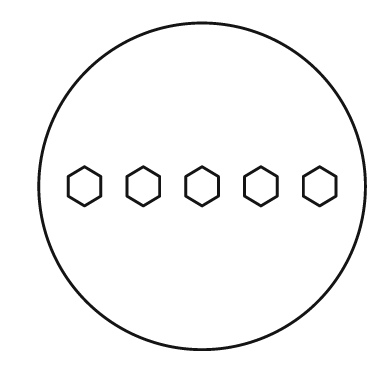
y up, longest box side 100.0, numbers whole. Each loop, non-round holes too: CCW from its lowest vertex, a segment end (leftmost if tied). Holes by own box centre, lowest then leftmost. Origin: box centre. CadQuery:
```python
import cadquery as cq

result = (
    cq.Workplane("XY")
    .moveTo(0.0, 0.0)
    .circle(50.0)
    .moveTo(-36.0, -6.0)
    .lineTo(-31.0, -3.0)
    .lineTo(-31.0, 3.0)
    .lineTo(-36.0, 6.0)
    .lineTo(-41.0, 3.0)
    .lineTo(-41.0, -3.0)
    .close()
    .moveTo(-18.0, -6.0)
    .lineTo(-13.0, -3.0)
    .lineTo(-13.0, 3.0)
    .lineTo(-18.0, 6.0)
    .lineTo(-23.0, 3.0)
    .lineTo(-23.0, -3.0)
    .close()
    .moveTo(0.0, -6.0)
    .lineTo(5.0, -3.0)
    .lineTo(5.0, 3.0)
    .lineTo(0.0, 6.0)
    .lineTo(-5.0, 3.0)
    .lineTo(-5.0, -3.0)
    .close()
    .moveTo(18.0, -6.0)
    .lineTo(23.0, -3.0)
    .lineTo(23.0, 3.0)
    .lineTo(18.0, 6.0)
    .lineTo(13.0, 3.0)
    .lineTo(13.0, -3.0)
    .close()
    .moveTo(36.0, -6.0)
    .lineTo(41.0, -3.0)
    .lineTo(41.0, 3.0)
    .lineTo(36.0, 6.0)
    .lineTo(31.0, 3.0)
    .lineTo(31.0, -3.0)
    .close()
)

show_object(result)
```